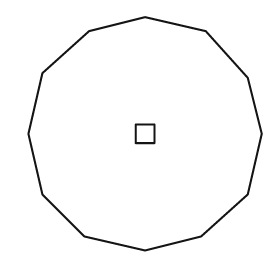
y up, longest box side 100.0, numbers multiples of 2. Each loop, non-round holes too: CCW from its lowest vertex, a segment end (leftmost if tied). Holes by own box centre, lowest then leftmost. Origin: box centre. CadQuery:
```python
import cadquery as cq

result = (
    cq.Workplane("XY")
    .moveTo(0.0, -50.0)
    .lineTo(24.0, -44.0)
    .lineTo(44.0, -26.0)
    .lineTo(50.0, 0.0)
    .lineTo(44.0, 24.0)
    .lineTo(26.0, 44.0)
    .lineTo(0.0, 50.0)
    .lineTo(-24.0, 44.0)
    .lineTo(-44.0, 26.0)
    .lineTo(-50.0, 0.0)
    .lineTo(-44.0, -26.0)
    .lineTo(-26.0, -44.0)
    .close()
    .moveTo(-4.0, -4.0)
    .lineTo(4.0, -4.0)
    .lineTo(4.0, 4.0)
    .lineTo(-4.0, 4.0)
    .close()
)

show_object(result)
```